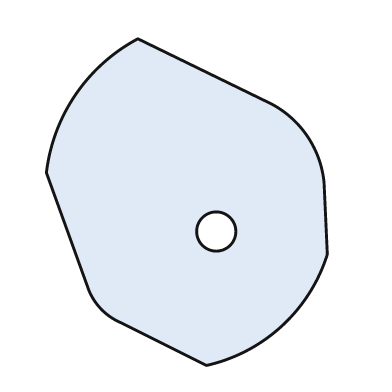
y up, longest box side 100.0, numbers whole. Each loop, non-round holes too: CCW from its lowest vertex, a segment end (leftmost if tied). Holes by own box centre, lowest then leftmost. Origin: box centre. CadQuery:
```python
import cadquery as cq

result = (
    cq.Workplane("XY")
    .moveTo(6.0, -50.0)
    .threePointArc((29.0, -38.0), (43.0, -16.0))
    .lineTo(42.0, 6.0)
    .threePointArc((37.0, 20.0), (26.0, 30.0))
    .lineTo(-15.0, 50.0)
    .threePointArc((-34.0, 33.0), (-43.0, 9.0))
    .lineTo(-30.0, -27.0)
    .threePointArc((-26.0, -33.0), (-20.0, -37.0))
    .close()
    .moveTo(9.0, -9.0)
    .circle(6.0)
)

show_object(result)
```